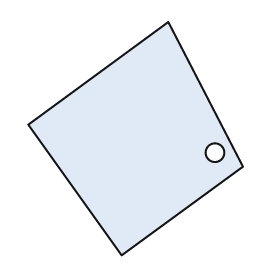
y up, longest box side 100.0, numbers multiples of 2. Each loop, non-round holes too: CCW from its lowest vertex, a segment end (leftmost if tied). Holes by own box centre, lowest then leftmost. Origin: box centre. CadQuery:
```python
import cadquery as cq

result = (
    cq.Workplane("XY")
    .moveTo(-6.0, -50.0)
    .lineTo(46.0, -12.0)
    .lineTo(14.0, 50.0)
    .lineTo(-46.0, 6.0)
    .close()
    .moveTo(34.0, -6.0)
    .circle(4.0)
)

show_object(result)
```